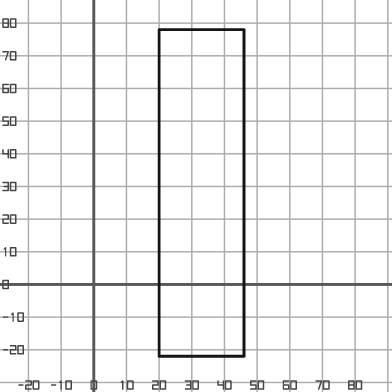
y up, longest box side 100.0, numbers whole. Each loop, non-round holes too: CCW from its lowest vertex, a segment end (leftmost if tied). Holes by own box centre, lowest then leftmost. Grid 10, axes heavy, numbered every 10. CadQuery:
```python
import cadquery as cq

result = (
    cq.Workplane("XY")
    .moveTo(20.0, -22.0)
    .lineTo(46.0, -22.0)
    .lineTo(46.0, 78.0)
    .lineTo(20.0, 78.0)
    .close()
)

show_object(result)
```